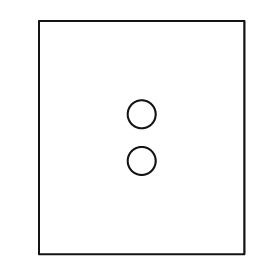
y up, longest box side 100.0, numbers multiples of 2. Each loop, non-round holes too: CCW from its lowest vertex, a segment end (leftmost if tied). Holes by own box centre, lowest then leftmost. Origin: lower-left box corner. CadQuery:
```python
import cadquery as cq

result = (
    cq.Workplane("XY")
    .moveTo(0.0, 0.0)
    .lineTo(88.0, 0.0)
    .lineTo(88.0, 100.0)
    .lineTo(0.0, 100.0)
    .close()
    .moveTo(44.0, 40.0)
    .circle(6.0)
    .moveTo(44.0, 60.0)
    .circle(6.0)
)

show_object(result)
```